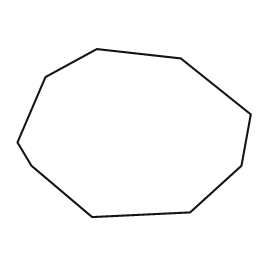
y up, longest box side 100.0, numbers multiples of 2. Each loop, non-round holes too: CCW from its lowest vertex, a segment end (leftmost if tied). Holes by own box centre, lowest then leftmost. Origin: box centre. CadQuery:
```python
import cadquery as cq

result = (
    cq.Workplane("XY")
    .moveTo(-18.0, -36.0)
    .lineTo(24.0, -34.0)
    .lineTo(46.0, -14.0)
    .lineTo(50.0, 8.0)
    .lineTo(20.0, 32.0)
    .lineTo(-16.0, 36.0)
    .lineTo(-38.0, 24.0)
    .lineTo(-50.0, -4.0)
    .lineTo(-44.0, -14.0)
    .close()
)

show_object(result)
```